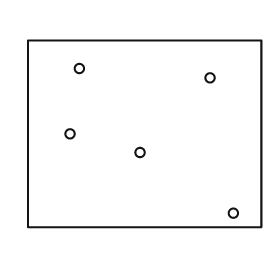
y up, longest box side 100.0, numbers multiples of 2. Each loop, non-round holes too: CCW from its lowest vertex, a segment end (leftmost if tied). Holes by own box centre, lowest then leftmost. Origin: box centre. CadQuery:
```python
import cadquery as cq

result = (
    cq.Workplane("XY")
    .moveTo(-50.0, -40.0)
    .lineTo(50.0, -40.0)
    .lineTo(50.0, 40.0)
    .lineTo(-50.0, 40.0)
    .close()
    .moveTo(38.0, -34.0)
    .circle(2.0)
    .moveTo(-2.0, -8.0)
    .circle(2.0)
    .moveTo(-32.0, 0.0)
    .circle(2.0)
    .moveTo(28.0, 24.0)
    .circle(2.0)
    .moveTo(-28.0, 28.0)
    .circle(2.0)
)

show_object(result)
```